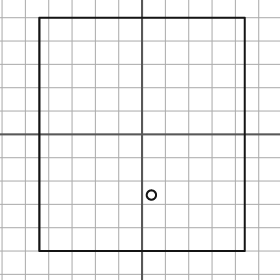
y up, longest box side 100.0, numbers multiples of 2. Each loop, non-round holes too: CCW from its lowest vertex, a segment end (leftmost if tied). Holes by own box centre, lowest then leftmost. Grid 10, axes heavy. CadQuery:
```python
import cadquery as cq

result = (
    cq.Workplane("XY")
    .moveTo(-44.0, -50.0)
    .lineTo(44.0, -50.0)
    .lineTo(44.0, 50.0)
    .lineTo(-44.0, 50.0)
    .close()
    .moveTo(4.0, -26.0)
    .circle(2.0)
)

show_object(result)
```